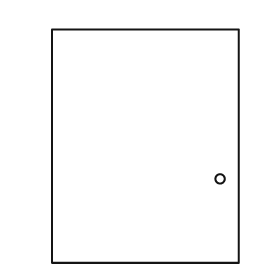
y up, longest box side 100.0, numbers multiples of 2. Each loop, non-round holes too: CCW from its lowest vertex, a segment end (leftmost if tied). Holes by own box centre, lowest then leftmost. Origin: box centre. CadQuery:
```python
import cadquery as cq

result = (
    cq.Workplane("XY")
    .moveTo(-40.0, -50.0)
    .lineTo(40.0, -50.0)
    .lineTo(40.0, 50.0)
    .lineTo(-40.0, 50.0)
    .close()
    .moveTo(32.0, -14.0)
    .circle(2.0)
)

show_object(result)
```